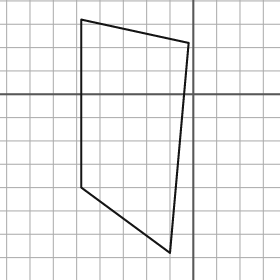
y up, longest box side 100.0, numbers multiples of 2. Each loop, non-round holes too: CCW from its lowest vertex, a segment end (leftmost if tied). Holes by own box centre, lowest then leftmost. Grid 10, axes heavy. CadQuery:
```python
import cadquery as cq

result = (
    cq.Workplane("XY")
    .moveTo(-10.0, -68.0)
    .lineTo(-2.0, 22.0)
    .lineTo(-48.0, 32.0)
    .lineTo(-48.0, -40.0)
    .close()
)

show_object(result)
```